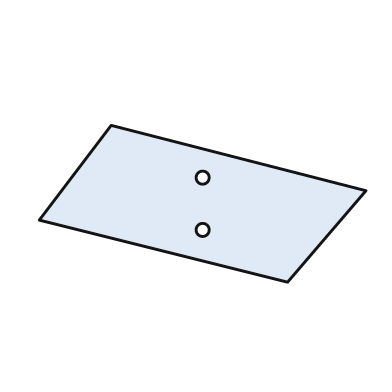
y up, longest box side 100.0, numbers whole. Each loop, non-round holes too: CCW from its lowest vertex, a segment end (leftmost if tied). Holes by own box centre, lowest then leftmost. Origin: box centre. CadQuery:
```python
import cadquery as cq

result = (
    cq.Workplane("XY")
    .moveTo(26.0, -24.0)
    .lineTo(50.0, 4.0)
    .lineTo(-28.0, 24.0)
    .lineTo(-50.0, -5.0)
    .close()
    .moveTo(0.0, -8.0)
    .circle(2.0)
    .moveTo(0.0, 8.0)
    .circle(2.0)
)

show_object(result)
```